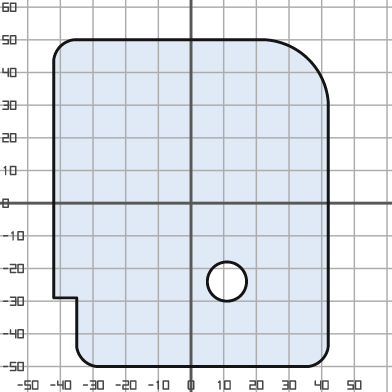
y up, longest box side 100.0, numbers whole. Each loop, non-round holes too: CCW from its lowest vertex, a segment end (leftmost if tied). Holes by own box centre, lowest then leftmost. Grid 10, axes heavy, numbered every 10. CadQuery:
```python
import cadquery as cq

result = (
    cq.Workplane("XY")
    .moveTo(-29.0, -50.0)
    .lineTo(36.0, -50.0)
    .threePointArc((40.0, -48.0), (42.0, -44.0))
    .lineTo(42.0, 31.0)
    .threePointArc((36.0, 44.0), (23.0, 50.0))
    .lineTo(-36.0, 50.0)
    .threePointArc((-40.0, 48.0), (-42.0, 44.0))
    .lineTo(-42.0, -29.0)
    .lineTo(-35.0, -29.0)
    .lineTo(-35.0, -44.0)
    .threePointArc((-33.0, -48.0), (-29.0, -50.0))
    .close()
    .moveTo(11.0, -24.0)
    .circle(6.0)
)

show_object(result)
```